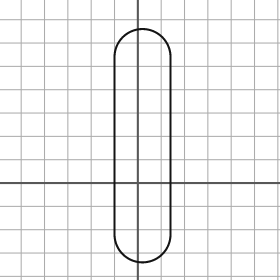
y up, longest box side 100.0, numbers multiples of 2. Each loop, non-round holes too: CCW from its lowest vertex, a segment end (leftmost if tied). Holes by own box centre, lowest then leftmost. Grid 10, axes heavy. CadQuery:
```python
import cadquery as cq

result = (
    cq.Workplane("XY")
    .moveTo(-10.0, -22.0)
    .threePointArc((2.0, -34.0), (14.0, -22.0))
    .lineTo(14.0, 54.0)
    .threePointArc((2.0, 66.0), (-10.0, 54.0))
    .close()
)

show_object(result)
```